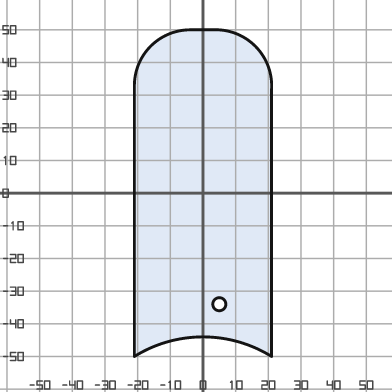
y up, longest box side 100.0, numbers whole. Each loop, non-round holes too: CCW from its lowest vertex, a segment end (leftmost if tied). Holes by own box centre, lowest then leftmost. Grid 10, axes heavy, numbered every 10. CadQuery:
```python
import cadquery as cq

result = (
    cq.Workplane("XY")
    .moveTo(-21.0, -50.0)
    .threePointArc((0.0, -44.0), (21.0, -50.0))
    .lineTo(21.0, 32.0)
    .threePointArc((16.0, 45.0), (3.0, 50.0))
    .lineTo(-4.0, 50.0)
    .threePointArc((-16.0, 45.0), (-21.0, 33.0))
    .close()
    .moveTo(5.0, -34.0)
    .circle(2.0)
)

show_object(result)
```